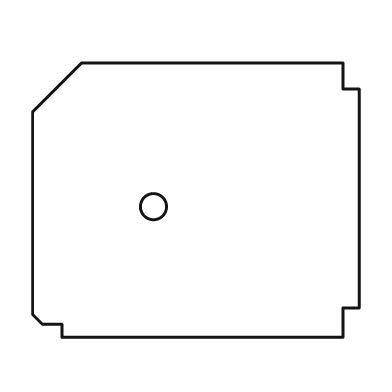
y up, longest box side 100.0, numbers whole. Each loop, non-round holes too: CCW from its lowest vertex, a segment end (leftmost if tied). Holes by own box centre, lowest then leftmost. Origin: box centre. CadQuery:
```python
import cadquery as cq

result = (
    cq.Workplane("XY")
    .moveTo(-41.0, -42.0)
    .lineTo(45.0, -42.0)
    .lineTo(45.0, -33.0)
    .lineTo(50.0, -33.0)
    .lineTo(50.0, 34.0)
    .lineTo(45.0, 34.0)
    .lineTo(45.0, 42.0)
    .lineTo(-35.0, 42.0)
    .lineTo(-50.0, 27.0)
    .lineTo(-50.0, -35.0)
    .lineTo(-47.0, -38.0)
    .lineTo(-41.0, -38.0)
    .close()
    .moveTo(-13.0, -2.0)
    .circle(4.0)
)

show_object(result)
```